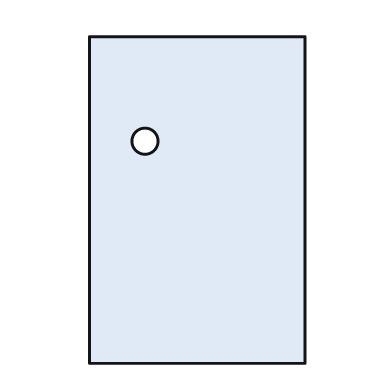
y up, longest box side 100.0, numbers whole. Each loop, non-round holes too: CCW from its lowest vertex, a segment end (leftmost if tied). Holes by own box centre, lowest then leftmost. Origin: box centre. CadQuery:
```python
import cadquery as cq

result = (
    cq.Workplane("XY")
    .moveTo(-33.0, -50.0)
    .lineTo(33.0, -50.0)
    .lineTo(33.0, 50.0)
    .lineTo(-33.0, 50.0)
    .close()
    .moveTo(-16.0, 18.0)
    .circle(4.0)
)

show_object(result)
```